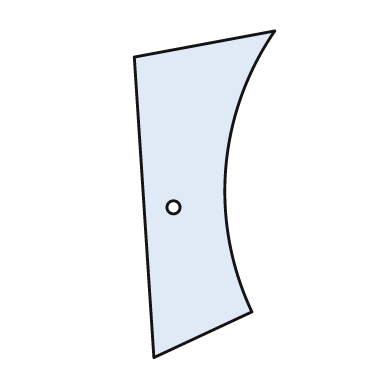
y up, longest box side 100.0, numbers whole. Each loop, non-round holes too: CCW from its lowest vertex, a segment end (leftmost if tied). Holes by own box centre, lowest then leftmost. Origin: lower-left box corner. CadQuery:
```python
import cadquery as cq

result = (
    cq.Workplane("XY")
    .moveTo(6.0, 0.0)
    .lineTo(36.0, 14.0)
    .threePointArc((28.0, 58.0), (43.0, 100.0))
    .lineTo(0.0, 92.0)
    .close()
    .moveTo(12.0, 46.0)
    .circle(2.0)
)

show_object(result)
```